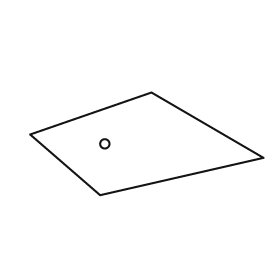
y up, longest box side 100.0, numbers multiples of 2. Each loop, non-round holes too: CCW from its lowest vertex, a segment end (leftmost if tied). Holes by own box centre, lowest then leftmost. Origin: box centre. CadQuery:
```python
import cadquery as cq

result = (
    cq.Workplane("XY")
    .moveTo(-20.0, -22.0)
    .lineTo(50.0, -6.0)
    .lineTo(2.0, 22.0)
    .lineTo(-50.0, 4.0)
    .close()
    .moveTo(-18.0, 0.0)
    .circle(2.0)
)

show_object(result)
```